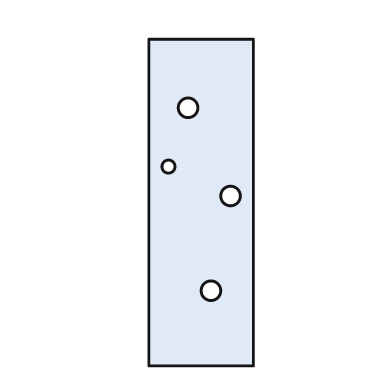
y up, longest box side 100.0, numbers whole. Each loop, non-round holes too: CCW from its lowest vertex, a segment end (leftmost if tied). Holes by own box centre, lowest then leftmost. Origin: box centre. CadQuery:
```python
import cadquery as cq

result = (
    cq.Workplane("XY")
    .moveTo(-16.0, -50.0)
    .lineTo(16.0, -50.0)
    .lineTo(16.0, 50.0)
    .lineTo(-16.0, 50.0)
    .close()
    .moveTo(3.0, -27.0)
    .circle(3.0)
    .moveTo(9.0, 2.0)
    .circle(3.0)
    .moveTo(-10.0, 11.0)
    .circle(2.0)
    .moveTo(-4.0, 29.0)
    .circle(3.0)
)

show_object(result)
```